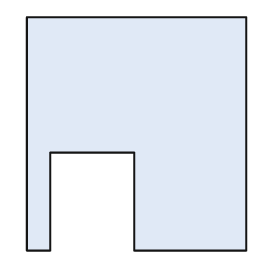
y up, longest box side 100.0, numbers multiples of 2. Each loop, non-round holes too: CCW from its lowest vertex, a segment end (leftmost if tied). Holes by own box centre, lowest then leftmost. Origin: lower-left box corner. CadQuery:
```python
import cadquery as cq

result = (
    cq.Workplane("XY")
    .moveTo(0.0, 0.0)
    .lineTo(10.0, 0.0)
    .lineTo(10.0, 42.0)
    .lineTo(46.0, 42.0)
    .lineTo(46.0, 0.0)
    .lineTo(94.0, 0.0)
    .lineTo(94.0, 100.0)
    .lineTo(0.0, 100.0)
    .close()
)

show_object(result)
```